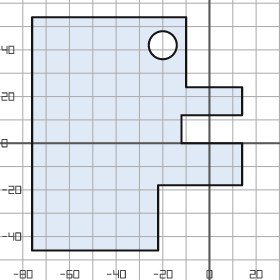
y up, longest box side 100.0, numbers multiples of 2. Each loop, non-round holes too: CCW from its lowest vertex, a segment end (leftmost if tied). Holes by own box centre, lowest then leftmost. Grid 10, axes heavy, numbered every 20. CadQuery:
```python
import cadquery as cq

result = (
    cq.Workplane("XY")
    .moveTo(-76.0, -46.0)
    .lineTo(-22.0, -46.0)
    .lineTo(-22.0, -18.0)
    .lineTo(14.0, -18.0)
    .lineTo(14.0, 0.0)
    .lineTo(-12.0, 0.0)
    .lineTo(-12.0, 12.0)
    .lineTo(14.0, 12.0)
    .lineTo(14.0, 24.0)
    .lineTo(-10.0, 24.0)
    .lineTo(-10.0, 54.0)
    .lineTo(-76.0, 54.0)
    .close()
    .moveTo(-20.0, 42.0)
    .circle(6.0)
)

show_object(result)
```